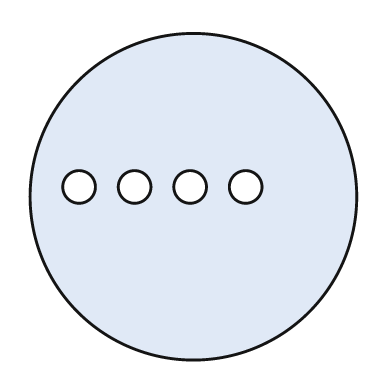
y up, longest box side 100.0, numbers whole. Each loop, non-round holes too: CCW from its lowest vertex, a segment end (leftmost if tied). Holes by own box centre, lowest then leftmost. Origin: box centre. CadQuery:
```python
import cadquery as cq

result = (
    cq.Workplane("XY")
    .moveTo(0.0, 0.0)
    .circle(50.0)
    .moveTo(-35.0, 3.0)
    .circle(5.0)
    .moveTo(-18.0, 3.0)
    .circle(5.0)
    .moveTo(-1.0, 3.0)
    .circle(5.0)
    .moveTo(16.0, 3.0)
    .circle(5.0)
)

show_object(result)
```